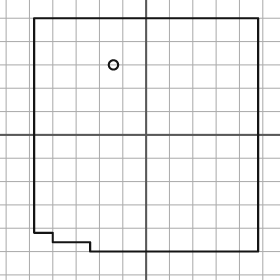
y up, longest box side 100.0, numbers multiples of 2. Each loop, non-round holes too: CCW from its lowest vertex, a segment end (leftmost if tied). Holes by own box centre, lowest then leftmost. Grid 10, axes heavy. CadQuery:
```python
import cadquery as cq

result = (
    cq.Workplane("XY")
    .moveTo(-24.0, -50.0)
    .lineTo(48.0, -50.0)
    .lineTo(48.0, 50.0)
    .lineTo(-48.0, 50.0)
    .lineTo(-48.0, -42.0)
    .lineTo(-40.0, -42.0)
    .lineTo(-40.0, -46.0)
    .lineTo(-24.0, -46.0)
    .close()
    .moveTo(-14.0, 30.0)
    .circle(2.0)
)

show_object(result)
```